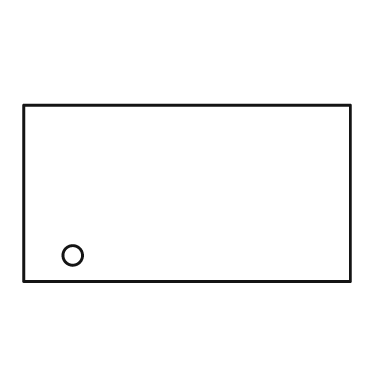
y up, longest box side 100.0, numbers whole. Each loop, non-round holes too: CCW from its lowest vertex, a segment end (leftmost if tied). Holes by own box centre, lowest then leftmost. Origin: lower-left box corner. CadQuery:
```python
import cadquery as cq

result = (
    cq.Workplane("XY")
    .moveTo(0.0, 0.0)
    .lineTo(100.0, 0.0)
    .lineTo(100.0, 54.0)
    .lineTo(0.0, 54.0)
    .close()
    .moveTo(15.0, 8.0)
    .circle(3.0)
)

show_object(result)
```